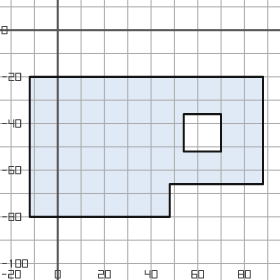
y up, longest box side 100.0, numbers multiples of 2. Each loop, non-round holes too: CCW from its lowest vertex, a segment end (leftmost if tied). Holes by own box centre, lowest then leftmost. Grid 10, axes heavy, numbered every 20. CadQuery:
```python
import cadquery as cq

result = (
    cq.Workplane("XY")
    .moveTo(-12.0, -80.0)
    .lineTo(48.0, -80.0)
    .lineTo(48.0, -66.0)
    .lineTo(88.0, -66.0)
    .lineTo(88.0, -20.0)
    .lineTo(-12.0, -20.0)
    .close()
    .moveTo(54.0, -52.0)
    .lineTo(70.0, -52.0)
    .lineTo(70.0, -36.0)
    .lineTo(54.0, -36.0)
    .close()
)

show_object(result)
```